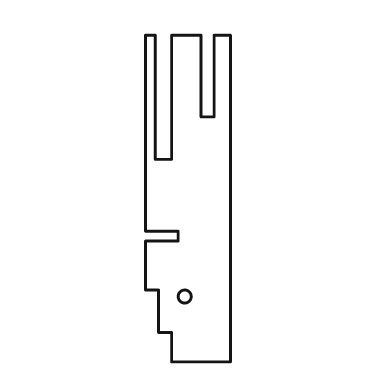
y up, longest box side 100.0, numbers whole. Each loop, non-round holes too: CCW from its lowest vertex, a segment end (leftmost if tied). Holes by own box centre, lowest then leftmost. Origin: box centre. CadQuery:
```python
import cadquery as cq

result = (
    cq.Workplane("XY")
    .moveTo(-5.0, -50.0)
    .lineTo(13.0, -50.0)
    .lineTo(13.0, 50.0)
    .lineTo(8.0, 50.0)
    .lineTo(8.0, 25.0)
    .lineTo(4.0, 25.0)
    .lineTo(4.0, 50.0)
    .lineTo(-5.0, 50.0)
    .lineTo(-5.0, 12.0)
    .lineTo(-10.0, 12.0)
    .lineTo(-10.0, 50.0)
    .lineTo(-13.0, 50.0)
    .lineTo(-13.0, -10.0)
    .lineTo(-3.0, -10.0)
    .lineTo(-3.0, -13.0)
    .lineTo(-13.0, -13.0)
    .lineTo(-13.0, -28.0)
    .lineTo(-9.0, -28.0)
    .lineTo(-9.0, -41.0)
    .lineTo(-5.0, -41.0)
    .close()
    .moveTo(-1.0, -30.0)
    .circle(2.0)
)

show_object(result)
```